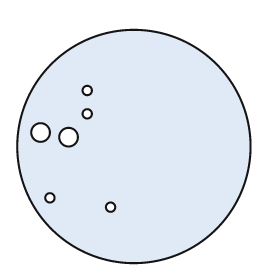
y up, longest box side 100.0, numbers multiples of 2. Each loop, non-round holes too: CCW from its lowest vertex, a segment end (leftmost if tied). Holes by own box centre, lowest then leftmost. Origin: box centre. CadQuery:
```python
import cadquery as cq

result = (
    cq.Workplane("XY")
    .moveTo(0.0, 0.0)
    .circle(50.0)
    .moveTo(-10.0, -26.0)
    .circle(2.0)
    .moveTo(-36.0, -22.0)
    .circle(2.0)
    .moveTo(-28.0, 4.0)
    .circle(4.0)
    .moveTo(-40.0, 6.0)
    .circle(4.0)
    .moveTo(-20.0, 14.0)
    .circle(2.0)
    .moveTo(-20.0, 24.0)
    .circle(2.0)
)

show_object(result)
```